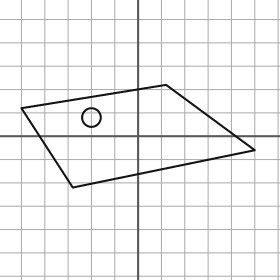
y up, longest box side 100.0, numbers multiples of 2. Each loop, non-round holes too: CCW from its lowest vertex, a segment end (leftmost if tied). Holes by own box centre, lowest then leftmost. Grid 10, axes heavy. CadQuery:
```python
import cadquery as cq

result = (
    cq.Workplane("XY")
    .moveTo(-28.0, -22.0)
    .lineTo(50.0, -6.0)
    .lineTo(12.0, 22.0)
    .lineTo(-50.0, 12.0)
    .close()
    .moveTo(-20.0, 8.0)
    .circle(4.0)
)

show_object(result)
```